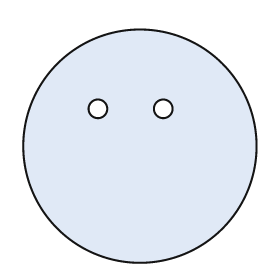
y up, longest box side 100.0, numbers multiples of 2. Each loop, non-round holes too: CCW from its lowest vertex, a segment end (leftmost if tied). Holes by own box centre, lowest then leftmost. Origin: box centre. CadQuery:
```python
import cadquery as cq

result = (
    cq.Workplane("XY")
    .moveTo(0.0, 0.0)
    .circle(50.0)
    .moveTo(-18.0, 16.0)
    .circle(4.0)
    .moveTo(10.0, 16.0)
    .circle(4.0)
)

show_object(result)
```